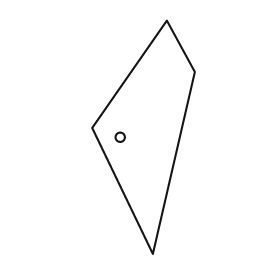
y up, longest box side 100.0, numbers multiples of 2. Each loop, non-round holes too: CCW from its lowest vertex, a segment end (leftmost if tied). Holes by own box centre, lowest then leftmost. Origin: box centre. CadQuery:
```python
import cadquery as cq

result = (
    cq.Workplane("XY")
    .moveTo(4.0, -50.0)
    .lineTo(22.0, 28.0)
    .lineTo(10.0, 50.0)
    .lineTo(-22.0, 4.0)
    .close()
    .moveTo(-10.0, 0.0)
    .circle(2.0)
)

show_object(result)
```